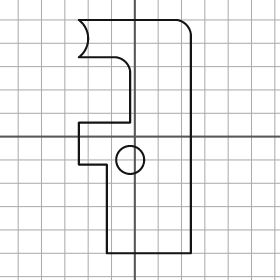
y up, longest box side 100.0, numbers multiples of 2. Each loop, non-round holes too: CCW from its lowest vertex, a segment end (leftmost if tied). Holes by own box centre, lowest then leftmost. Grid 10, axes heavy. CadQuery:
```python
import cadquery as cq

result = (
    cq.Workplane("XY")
    .moveTo(-12.0, -50.0)
    .lineTo(24.0, -50.0)
    .lineTo(24.0, 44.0)
    .threePointArc((22.0, 48.0), (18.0, 50.0))
    .lineTo(-24.0, 50.0)
    .threePointArc((-20.0, 42.0), (-24.0, 34.0))
    .lineTo(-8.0, 34.0)
    .threePointArc((-4.0, 32.0), (-2.0, 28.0))
    .lineTo(-2.0, 6.0)
    .lineTo(-24.0, 6.0)
    .lineTo(-24.0, -12.0)
    .lineTo(-12.0, -12.0)
    .close()
    .moveTo(-2.0, -10.0)
    .circle(6.0)
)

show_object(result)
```